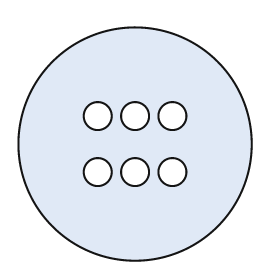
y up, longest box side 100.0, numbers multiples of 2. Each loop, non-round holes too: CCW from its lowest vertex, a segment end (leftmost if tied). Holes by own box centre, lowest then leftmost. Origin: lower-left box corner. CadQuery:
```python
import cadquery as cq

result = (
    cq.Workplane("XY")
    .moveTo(50.0, 50.0)
    .circle(50.0)
    .moveTo(34.0, 38.0)
    .circle(6.0)
    .moveTo(50.0, 38.0)
    .circle(6.0)
    .moveTo(66.0, 38.0)
    .circle(6.0)
    .moveTo(34.0, 62.0)
    .circle(6.0)
    .moveTo(50.0, 62.0)
    .circle(6.0)
    .moveTo(66.0, 62.0)
    .circle(6.0)
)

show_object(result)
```